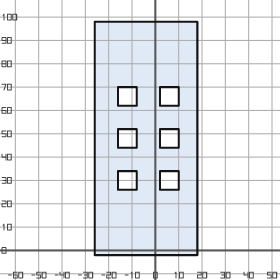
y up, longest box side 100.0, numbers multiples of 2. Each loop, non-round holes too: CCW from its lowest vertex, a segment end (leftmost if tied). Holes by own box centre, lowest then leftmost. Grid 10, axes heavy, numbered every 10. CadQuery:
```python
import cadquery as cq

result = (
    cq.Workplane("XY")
    .moveTo(-26.0, -2.0)
    .lineTo(18.0, -2.0)
    .lineTo(18.0, 98.0)
    .lineTo(-26.0, 98.0)
    .close()
    .moveTo(-16.0, 26.0)
    .lineTo(-8.0, 26.0)
    .lineTo(-8.0, 34.0)
    .lineTo(-16.0, 34.0)
    .close()
    .moveTo(2.0, 26.0)
    .lineTo(10.0, 26.0)
    .lineTo(10.0, 34.0)
    .lineTo(2.0, 34.0)
    .close()
    .moveTo(-16.0, 44.0)
    .lineTo(-8.0, 44.0)
    .lineTo(-8.0, 52.0)
    .lineTo(-16.0, 52.0)
    .close()
    .moveTo(2.0, 44.0)
    .lineTo(10.0, 44.0)
    .lineTo(10.0, 52.0)
    .lineTo(2.0, 52.0)
    .close()
    .moveTo(-16.0, 62.0)
    .lineTo(-8.0, 62.0)
    .lineTo(-8.0, 70.0)
    .lineTo(-16.0, 70.0)
    .close()
    .moveTo(2.0, 62.0)
    .lineTo(10.0, 62.0)
    .lineTo(10.0, 70.0)
    .lineTo(2.0, 70.0)
    .close()
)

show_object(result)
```